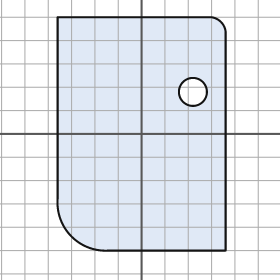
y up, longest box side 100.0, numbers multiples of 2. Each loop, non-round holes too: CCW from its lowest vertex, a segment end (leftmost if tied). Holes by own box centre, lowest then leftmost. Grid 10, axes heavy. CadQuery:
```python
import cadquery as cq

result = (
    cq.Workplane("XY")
    .moveTo(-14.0, -50.0)
    .lineTo(36.0, -50.0)
    .lineTo(36.0, 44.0)
    .threePointArc((34.0, 48.0), (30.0, 50.0))
    .lineTo(-36.0, 50.0)
    .lineTo(-36.0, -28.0)
    .threePointArc((-30.0, -44.0), (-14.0, -50.0))
    .close()
    .moveTo(22.0, 18.0)
    .circle(6.0)
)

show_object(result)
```